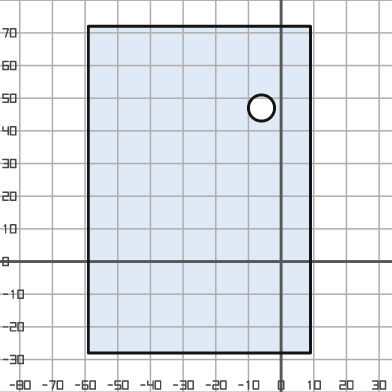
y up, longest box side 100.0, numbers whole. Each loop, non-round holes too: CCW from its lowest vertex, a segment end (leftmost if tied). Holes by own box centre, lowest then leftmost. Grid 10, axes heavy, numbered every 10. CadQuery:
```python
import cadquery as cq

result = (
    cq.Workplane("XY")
    .moveTo(-59.0, -28.0)
    .lineTo(9.0, -28.0)
    .lineTo(9.0, 72.0)
    .lineTo(-59.0, 72.0)
    .close()
    .moveTo(-6.0, 47.0)
    .circle(4.0)
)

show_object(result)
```